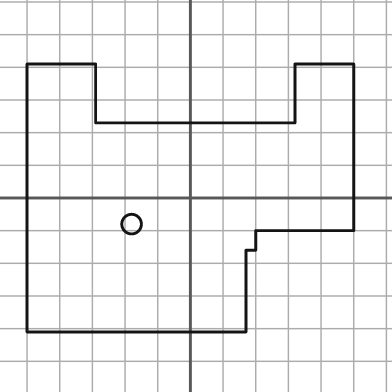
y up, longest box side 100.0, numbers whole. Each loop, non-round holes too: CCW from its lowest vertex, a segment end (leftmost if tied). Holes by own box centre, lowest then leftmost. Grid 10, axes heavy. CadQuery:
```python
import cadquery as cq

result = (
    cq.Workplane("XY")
    .moveTo(-50.0, -41.0)
    .lineTo(17.0, -41.0)
    .lineTo(17.0, -16.0)
    .lineTo(20.0, -16.0)
    .lineTo(20.0, -10.0)
    .lineTo(50.0, -10.0)
    .lineTo(50.0, 41.0)
    .lineTo(32.0, 41.0)
    .lineTo(32.0, 23.0)
    .lineTo(-29.0, 23.0)
    .lineTo(-29.0, 41.0)
    .lineTo(-50.0, 41.0)
    .close()
    .moveTo(-18.0, -8.0)
    .circle(3.0)
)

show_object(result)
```